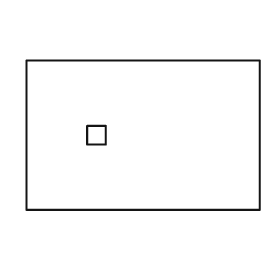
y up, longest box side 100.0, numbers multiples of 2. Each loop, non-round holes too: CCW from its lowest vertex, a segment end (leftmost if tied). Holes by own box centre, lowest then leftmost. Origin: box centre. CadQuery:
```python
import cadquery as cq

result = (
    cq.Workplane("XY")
    .moveTo(-50.0, -32.0)
    .lineTo(50.0, -32.0)
    .lineTo(50.0, 32.0)
    .lineTo(-50.0, 32.0)
    .close()
    .moveTo(-24.0, -4.0)
    .lineTo(-16.0, -4.0)
    .lineTo(-16.0, 4.0)
    .lineTo(-24.0, 4.0)
    .close()
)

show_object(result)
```